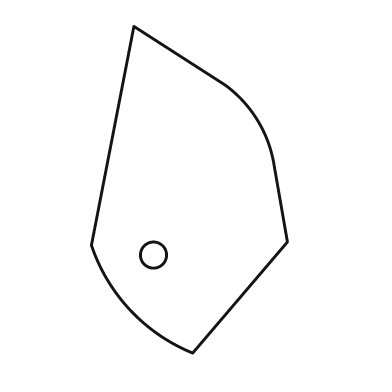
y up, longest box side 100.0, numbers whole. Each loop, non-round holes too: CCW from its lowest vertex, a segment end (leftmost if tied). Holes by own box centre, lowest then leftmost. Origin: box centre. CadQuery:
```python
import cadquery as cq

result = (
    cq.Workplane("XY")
    .moveTo(1.0, -50.0)
    .lineTo(30.0, -16.0)
    .lineTo(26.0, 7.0)
    .threePointArc((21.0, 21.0), (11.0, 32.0))
    .lineTo(-17.0, 50.0)
    .lineTo(-30.0, -17.0)
    .threePointArc((-18.0, -37.0), (1.0, -50.0))
    .close()
    .moveTo(-11.0, -20.0)
    .circle(4.0)
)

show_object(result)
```